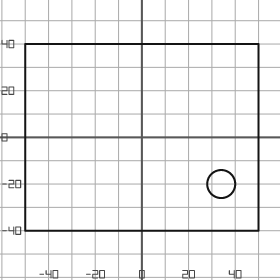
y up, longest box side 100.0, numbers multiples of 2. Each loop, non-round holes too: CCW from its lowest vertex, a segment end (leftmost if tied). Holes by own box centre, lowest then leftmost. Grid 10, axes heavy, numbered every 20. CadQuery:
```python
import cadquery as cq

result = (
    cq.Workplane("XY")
    .moveTo(-50.0, -40.0)
    .lineTo(50.0, -40.0)
    .lineTo(50.0, 40.0)
    .lineTo(-50.0, 40.0)
    .close()
    .moveTo(34.0, -20.0)
    .circle(6.0)
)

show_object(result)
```